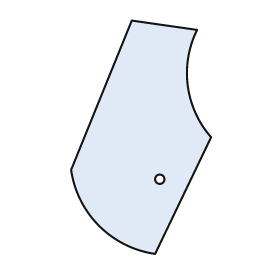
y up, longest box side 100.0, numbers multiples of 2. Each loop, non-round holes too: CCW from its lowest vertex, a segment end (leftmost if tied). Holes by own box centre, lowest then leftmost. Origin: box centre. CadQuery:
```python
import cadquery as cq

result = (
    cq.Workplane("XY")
    .moveTo(6.0, -50.0)
    .lineTo(30.0, 0.0)
    .threePointArc((20.0, 22.0), (24.0, 46.0))
    .lineTo(-4.0, 50.0)
    .lineTo(-30.0, -14.0)
    .threePointArc((-18.0, -38.0), (6.0, -50.0))
    .close()
    .moveTo(8.0, -18.0)
    .circle(2.0)
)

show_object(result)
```